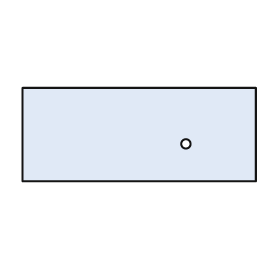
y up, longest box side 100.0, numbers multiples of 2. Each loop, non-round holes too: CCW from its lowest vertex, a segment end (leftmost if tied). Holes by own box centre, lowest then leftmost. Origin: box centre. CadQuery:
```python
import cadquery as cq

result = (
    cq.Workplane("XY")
    .moveTo(-50.0, -20.0)
    .lineTo(50.0, -20.0)
    .lineTo(50.0, 20.0)
    .lineTo(-50.0, 20.0)
    .close()
    .moveTo(20.0, -4.0)
    .circle(2.0)
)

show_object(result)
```